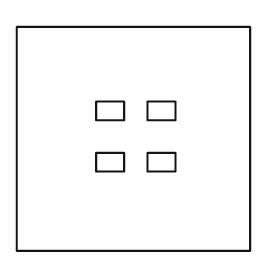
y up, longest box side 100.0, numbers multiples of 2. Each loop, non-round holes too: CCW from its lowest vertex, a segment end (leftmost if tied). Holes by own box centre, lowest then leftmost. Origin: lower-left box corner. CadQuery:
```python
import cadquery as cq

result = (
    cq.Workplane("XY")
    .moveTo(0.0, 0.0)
    .lineTo(100.0, 0.0)
    .lineTo(100.0, 96.0)
    .lineTo(0.0, 96.0)
    .close()
    .moveTo(34.0, 34.0)
    .lineTo(46.0, 34.0)
    .lineTo(46.0, 42.0)
    .lineTo(34.0, 42.0)
    .close()
    .moveTo(56.0, 34.0)
    .lineTo(68.0, 34.0)
    .lineTo(68.0, 42.0)
    .lineTo(56.0, 42.0)
    .close()
    .moveTo(34.0, 56.0)
    .lineTo(46.0, 56.0)
    .lineTo(46.0, 64.0)
    .lineTo(34.0, 64.0)
    .close()
    .moveTo(56.0, 56.0)
    .lineTo(68.0, 56.0)
    .lineTo(68.0, 64.0)
    .lineTo(56.0, 64.0)
    .close()
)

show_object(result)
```